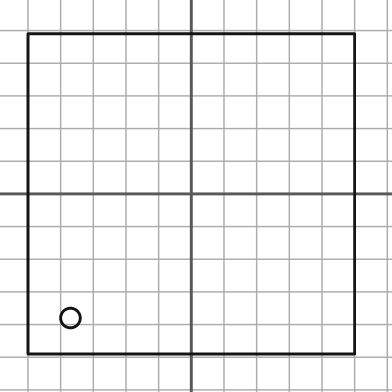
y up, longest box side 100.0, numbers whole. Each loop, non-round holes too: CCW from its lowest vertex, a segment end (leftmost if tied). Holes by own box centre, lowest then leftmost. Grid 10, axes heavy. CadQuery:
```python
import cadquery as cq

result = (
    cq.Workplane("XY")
    .moveTo(-50.0, -49.0)
    .lineTo(50.0, -49.0)
    .lineTo(50.0, 49.0)
    .lineTo(-50.0, 49.0)
    .close()
    .moveTo(-37.0, -38.0)
    .circle(3.0)
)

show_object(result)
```